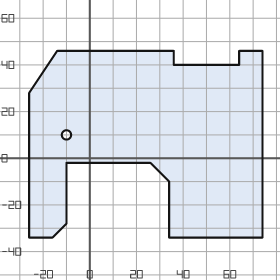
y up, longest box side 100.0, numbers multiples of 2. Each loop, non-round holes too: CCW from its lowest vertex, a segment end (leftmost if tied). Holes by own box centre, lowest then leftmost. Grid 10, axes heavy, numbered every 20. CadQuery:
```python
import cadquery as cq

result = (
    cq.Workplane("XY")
    .moveTo(-26.0, -34.0)
    .lineTo(-16.0, -34.0)
    .lineTo(-10.0, -28.0)
    .lineTo(-10.0, -2.0)
    .lineTo(26.0, -2.0)
    .lineTo(34.0, -10.0)
    .lineTo(34.0, -34.0)
    .lineTo(74.0, -34.0)
    .lineTo(74.0, 46.0)
    .lineTo(64.0, 46.0)
    .lineTo(64.0, 40.0)
    .lineTo(36.0, 40.0)
    .lineTo(36.0, 46.0)
    .lineTo(-14.0, 46.0)
    .lineTo(-26.0, 28.0)
    .close()
    .moveTo(-10.0, 10.0)
    .circle(2.0)
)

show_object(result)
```